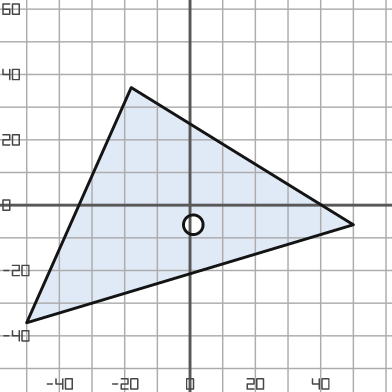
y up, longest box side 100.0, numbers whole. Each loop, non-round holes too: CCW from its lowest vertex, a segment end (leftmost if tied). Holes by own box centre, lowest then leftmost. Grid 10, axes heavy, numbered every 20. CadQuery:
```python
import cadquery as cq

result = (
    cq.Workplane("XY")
    .moveTo(-50.0, -36.0)
    .lineTo(50.0, -6.0)
    .lineTo(-18.0, 36.0)
    .close()
    .moveTo(1.0, -6.0)
    .circle(3.0)
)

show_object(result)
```